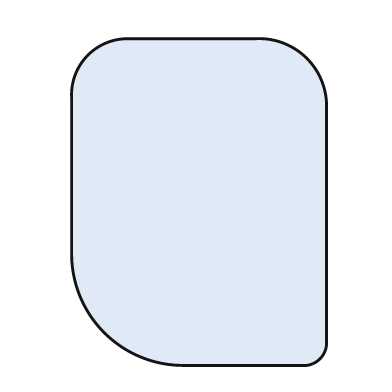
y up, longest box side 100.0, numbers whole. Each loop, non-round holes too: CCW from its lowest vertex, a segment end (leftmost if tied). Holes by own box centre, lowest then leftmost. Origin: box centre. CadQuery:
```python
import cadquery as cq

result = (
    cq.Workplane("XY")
    .moveTo(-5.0, -50.0)
    .lineTo(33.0, -50.0)
    .threePointArc((37.0, -48.0), (39.0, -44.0))
    .lineTo(39.0, 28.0)
    .threePointArc((33.0, 44.0), (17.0, 50.0))
    .lineTo(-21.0, 50.0)
    .threePointArc((-34.0, 45.0), (-39.0, 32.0))
    .lineTo(-39.0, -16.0)
    .threePointArc((-29.0, -40.0), (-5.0, -50.0))
    .close()
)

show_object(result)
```